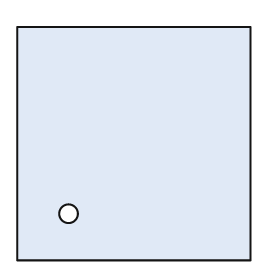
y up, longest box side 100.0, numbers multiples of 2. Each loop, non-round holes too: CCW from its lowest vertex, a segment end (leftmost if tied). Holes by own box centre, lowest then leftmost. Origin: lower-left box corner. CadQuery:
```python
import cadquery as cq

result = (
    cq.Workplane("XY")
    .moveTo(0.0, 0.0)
    .lineTo(100.0, 0.0)
    .lineTo(100.0, 100.0)
    .lineTo(0.0, 100.0)
    .close()
    .moveTo(22.0, 20.0)
    .circle(4.0)
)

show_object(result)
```